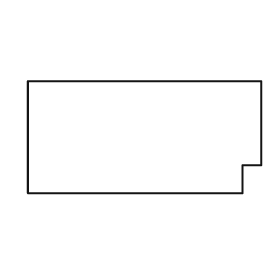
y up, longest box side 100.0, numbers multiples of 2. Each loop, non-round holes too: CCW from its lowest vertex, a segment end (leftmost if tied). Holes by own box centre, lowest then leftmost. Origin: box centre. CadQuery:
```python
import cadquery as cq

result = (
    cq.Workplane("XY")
    .moveTo(-50.0, -24.0)
    .lineTo(42.0, -24.0)
    .lineTo(42.0, -12.0)
    .lineTo(50.0, -12.0)
    .lineTo(50.0, 24.0)
    .lineTo(-50.0, 24.0)
    .close()
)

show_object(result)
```